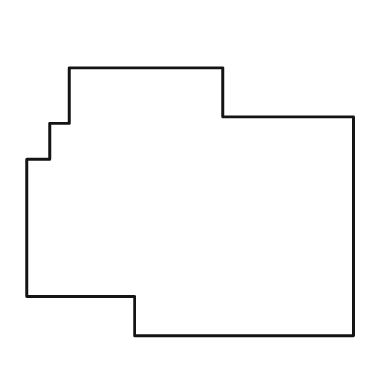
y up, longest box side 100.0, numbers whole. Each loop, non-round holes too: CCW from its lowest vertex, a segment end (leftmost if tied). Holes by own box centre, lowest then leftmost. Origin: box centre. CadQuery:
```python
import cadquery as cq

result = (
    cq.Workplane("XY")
    .moveTo(-17.0, -41.0)
    .lineTo(50.0, -41.0)
    .lineTo(50.0, 26.0)
    .lineTo(10.0, 26.0)
    .lineTo(10.0, 41.0)
    .lineTo(-37.0, 41.0)
    .lineTo(-37.0, 24.0)
    .lineTo(-43.0, 24.0)
    .lineTo(-43.0, 13.0)
    .lineTo(-50.0, 13.0)
    .lineTo(-50.0, -29.0)
    .lineTo(-17.0, -29.0)
    .close()
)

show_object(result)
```